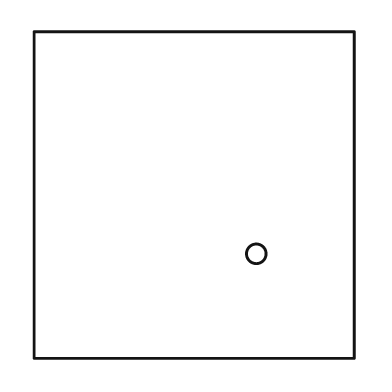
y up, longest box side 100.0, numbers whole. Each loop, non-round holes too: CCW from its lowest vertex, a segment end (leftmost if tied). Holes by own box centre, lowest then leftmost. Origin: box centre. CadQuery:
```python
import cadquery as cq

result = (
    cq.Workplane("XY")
    .moveTo(-49.0, -50.0)
    .lineTo(49.0, -50.0)
    .lineTo(49.0, 50.0)
    .lineTo(-49.0, 50.0)
    .close()
    .moveTo(19.0, -18.0)
    .circle(3.0)
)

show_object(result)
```